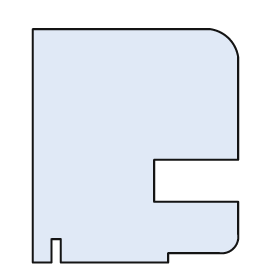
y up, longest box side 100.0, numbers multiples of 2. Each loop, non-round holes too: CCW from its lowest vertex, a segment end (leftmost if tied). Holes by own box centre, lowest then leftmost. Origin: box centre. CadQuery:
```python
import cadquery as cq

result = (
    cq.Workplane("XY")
    .moveTo(-44.0, -50.0)
    .lineTo(-36.0, -50.0)
    .lineTo(-36.0, -40.0)
    .lineTo(-32.0, -40.0)
    .lineTo(-32.0, -50.0)
    .lineTo(14.0, -50.0)
    .lineTo(14.0, -46.0)
    .lineTo(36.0, -46.0)
    .threePointArc((42.0, -44.0), (44.0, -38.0))
    .lineTo(44.0, -24.0)
    .lineTo(8.0, -24.0)
    .lineTo(8.0, -6.0)
    .lineTo(44.0, -6.0)
    .lineTo(44.0, 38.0)
    .threePointArc((40.0, 46.0), (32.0, 50.0))
    .lineTo(-44.0, 50.0)
    .close()
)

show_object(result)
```